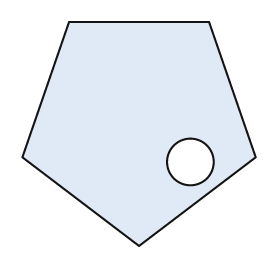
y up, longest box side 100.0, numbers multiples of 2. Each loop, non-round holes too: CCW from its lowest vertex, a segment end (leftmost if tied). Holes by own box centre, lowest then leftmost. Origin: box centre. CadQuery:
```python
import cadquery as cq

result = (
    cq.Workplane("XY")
    .moveTo(0.0, -48.0)
    .lineTo(50.0, -10.0)
    .lineTo(30.0, 48.0)
    .lineTo(-30.0, 48.0)
    .lineTo(-50.0, -10.0)
    .close()
    .moveTo(22.0, -12.0)
    .circle(10.0)
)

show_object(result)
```